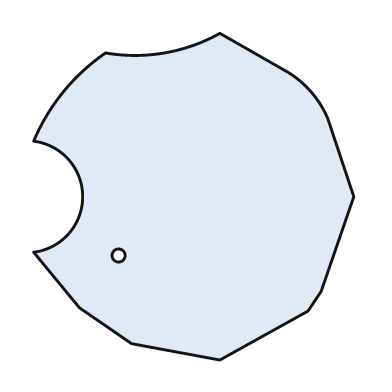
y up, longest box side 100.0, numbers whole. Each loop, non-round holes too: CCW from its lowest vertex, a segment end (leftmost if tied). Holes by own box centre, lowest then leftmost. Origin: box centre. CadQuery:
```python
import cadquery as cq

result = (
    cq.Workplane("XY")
    .moveTo(8.0, -50.0)
    .lineTo(35.0, -35.0)
    .lineTo(39.0, -29.0)
    .lineTo(49.0, 0.0)
    .lineTo(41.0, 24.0)
    .threePointArc((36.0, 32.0), (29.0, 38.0))
    .lineTo(8.0, 50.0)
    .threePointArc((-9.0, 44.0), (-27.0, 44.0))
    .threePointArc((-40.0, 32.0), (-49.0, 17.0))
    .threePointArc((-34.0, 0.0), (-49.0, -17.0))
    .lineTo(-35.0, -34.0)
    .lineTo(-19.0, -45.0)
    .close()
    .moveTo(-23.0, -18.0)
    .circle(2.0)
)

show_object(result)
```